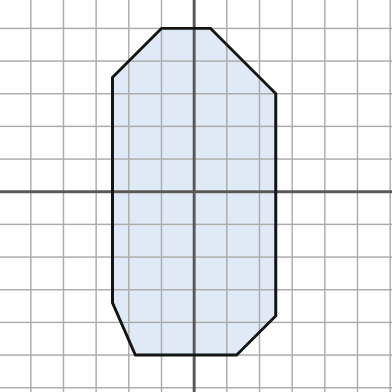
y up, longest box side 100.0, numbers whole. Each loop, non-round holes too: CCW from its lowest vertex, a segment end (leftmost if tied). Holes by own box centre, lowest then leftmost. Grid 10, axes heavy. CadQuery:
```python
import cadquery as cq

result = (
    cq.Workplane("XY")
    .moveTo(-18.0, -50.0)
    .lineTo(13.0, -50.0)
    .lineTo(25.0, -38.0)
    .lineTo(25.0, 30.0)
    .lineTo(5.0, 50.0)
    .lineTo(-10.0, 50.0)
    .lineTo(-25.0, 35.0)
    .lineTo(-25.0, -34.0)
    .close()
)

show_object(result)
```